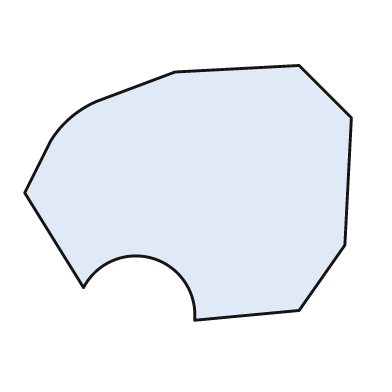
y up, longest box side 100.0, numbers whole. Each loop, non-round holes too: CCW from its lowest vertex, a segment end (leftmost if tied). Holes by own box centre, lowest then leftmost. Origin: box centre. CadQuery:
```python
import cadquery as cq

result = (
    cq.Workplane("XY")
    .moveTo(2.0, -39.0)
    .lineTo(34.0, -36.0)
    .lineTo(48.0, -16.0)
    .lineTo(50.0, 23.0)
    .lineTo(34.0, 39.0)
    .lineTo(-4.0, 37.0)
    .lineTo(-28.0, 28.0)
    .threePointArc((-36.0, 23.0), (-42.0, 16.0))
    .lineTo(-50.0, 0.0)
    .lineTo(-32.0, -29.0)
    .threePointArc((-11.0, -20.0), (2.0, -39.0))
    .close()
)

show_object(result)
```